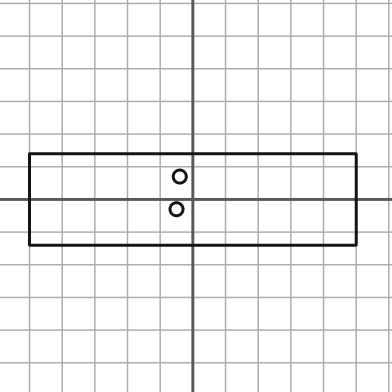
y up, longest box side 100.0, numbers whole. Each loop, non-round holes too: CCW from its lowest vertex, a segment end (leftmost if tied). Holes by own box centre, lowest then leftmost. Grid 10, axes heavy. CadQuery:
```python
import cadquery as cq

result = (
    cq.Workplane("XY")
    .moveTo(-50.0, -14.0)
    .lineTo(50.0, -14.0)
    .lineTo(50.0, 14.0)
    .lineTo(-50.0, 14.0)
    .close()
    .moveTo(-5.0, -3.0)
    .circle(2.0)
    .moveTo(-4.0, 7.0)
    .circle(2.0)
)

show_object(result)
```